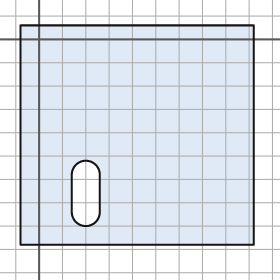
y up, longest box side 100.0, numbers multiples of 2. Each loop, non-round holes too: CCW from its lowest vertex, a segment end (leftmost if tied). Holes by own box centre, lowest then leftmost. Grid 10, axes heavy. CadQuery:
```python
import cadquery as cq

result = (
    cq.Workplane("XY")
    .moveTo(-8.0, -88.0)
    .lineTo(92.0, -88.0)
    .lineTo(92.0, 6.0)
    .lineTo(-8.0, 6.0)
    .close()
    .moveTo(14.0, -74.0)
    .threePointArc((20.0, -80.0), (26.0, -74.0))
    .lineTo(26.0, -58.0)
    .threePointArc((20.0, -52.0), (14.0, -58.0))
    .close()
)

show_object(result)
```